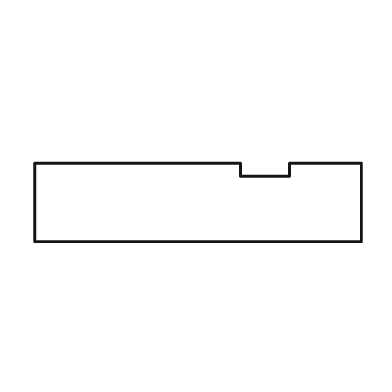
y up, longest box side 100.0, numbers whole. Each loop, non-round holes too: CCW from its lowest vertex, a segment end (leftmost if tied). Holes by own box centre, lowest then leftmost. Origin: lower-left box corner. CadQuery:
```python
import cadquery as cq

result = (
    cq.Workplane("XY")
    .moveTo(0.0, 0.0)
    .lineTo(100.0, 0.0)
    .lineTo(100.0, 24.0)
    .lineTo(78.0, 24.0)
    .lineTo(78.0, 20.0)
    .lineTo(63.0, 20.0)
    .lineTo(63.0, 24.0)
    .lineTo(0.0, 24.0)
    .close()
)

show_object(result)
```